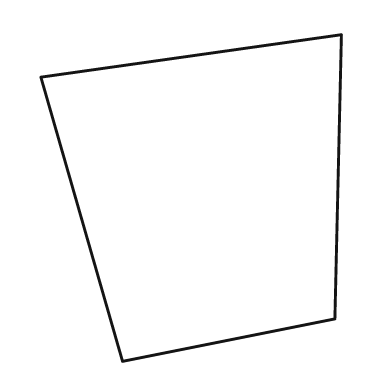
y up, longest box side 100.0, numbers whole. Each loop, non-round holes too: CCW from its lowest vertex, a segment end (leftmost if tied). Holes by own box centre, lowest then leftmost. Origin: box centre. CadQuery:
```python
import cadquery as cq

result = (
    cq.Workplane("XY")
    .moveTo(-21.0, -50.0)
    .lineTo(44.0, -37.0)
    .lineTo(46.0, 50.0)
    .lineTo(-46.0, 37.0)
    .close()
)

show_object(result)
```